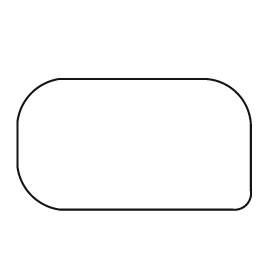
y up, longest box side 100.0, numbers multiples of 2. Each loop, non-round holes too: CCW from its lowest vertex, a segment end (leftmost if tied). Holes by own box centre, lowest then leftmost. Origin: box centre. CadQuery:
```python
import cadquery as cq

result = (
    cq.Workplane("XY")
    .moveTo(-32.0, -28.0)
    .lineTo(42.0, -28.0)
    .threePointArc((48.0, -26.0), (50.0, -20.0))
    .lineTo(50.0, 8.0)
    .threePointArc((44.0, 22.0), (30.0, 28.0))
    .lineTo(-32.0, 28.0)
    .threePointArc((-44.0, 22.0), (-50.0, 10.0))
    .lineTo(-50.0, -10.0)
    .threePointArc((-44.0, -22.0), (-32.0, -28.0))
    .close()
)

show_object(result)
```